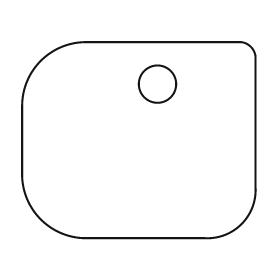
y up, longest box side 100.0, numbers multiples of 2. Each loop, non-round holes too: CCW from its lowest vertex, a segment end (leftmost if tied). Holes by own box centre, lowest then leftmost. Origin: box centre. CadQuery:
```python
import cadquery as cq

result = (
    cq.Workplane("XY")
    .moveTo(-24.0, -42.0)
    .lineTo(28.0, -42.0)
    .threePointArc((44.0, -36.0), (50.0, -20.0))
    .lineTo(50.0, 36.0)
    .threePointArc((48.0, 40.0), (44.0, 42.0))
    .lineTo(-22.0, 42.0)
    .threePointArc((-42.0, 34.0), (-50.0, 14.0))
    .lineTo(-50.0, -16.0)
    .threePointArc((-42.0, -34.0), (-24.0, -42.0))
    .close()
    .moveTo(8.0, 24.0)
    .circle(8.0)
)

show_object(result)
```